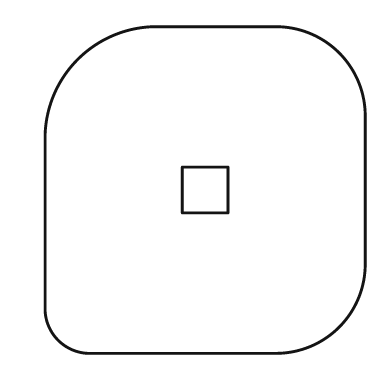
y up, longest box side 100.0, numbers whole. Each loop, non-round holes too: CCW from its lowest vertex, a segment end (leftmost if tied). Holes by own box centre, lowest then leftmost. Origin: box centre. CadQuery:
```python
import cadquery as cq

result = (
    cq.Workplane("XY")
    .moveTo(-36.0, -50.0)
    .lineTo(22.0, -50.0)
    .threePointArc((41.0, -42.0), (49.0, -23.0))
    .lineTo(49.0, 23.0)
    .threePointArc((41.0, 42.0), (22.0, 50.0))
    .lineTo(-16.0, 50.0)
    .threePointArc((-39.0, 40.0), (-49.0, 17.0))
    .lineTo(-49.0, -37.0)
    .threePointArc((-45.0, -46.0), (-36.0, -50.0))
    .close()
    .moveTo(-7.0, -7.0)
    .lineTo(7.0, -7.0)
    .lineTo(7.0, 7.0)
    .lineTo(-7.0, 7.0)
    .close()
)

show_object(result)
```